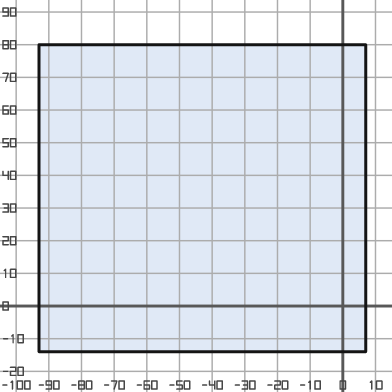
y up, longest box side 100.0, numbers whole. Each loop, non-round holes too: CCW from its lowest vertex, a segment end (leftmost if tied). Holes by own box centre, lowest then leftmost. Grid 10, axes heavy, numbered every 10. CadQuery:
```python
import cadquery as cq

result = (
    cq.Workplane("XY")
    .moveTo(-93.0, -14.0)
    .lineTo(7.0, -14.0)
    .lineTo(7.0, 80.0)
    .lineTo(-93.0, 80.0)
    .close()
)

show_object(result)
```